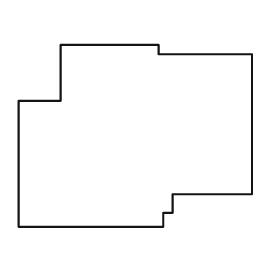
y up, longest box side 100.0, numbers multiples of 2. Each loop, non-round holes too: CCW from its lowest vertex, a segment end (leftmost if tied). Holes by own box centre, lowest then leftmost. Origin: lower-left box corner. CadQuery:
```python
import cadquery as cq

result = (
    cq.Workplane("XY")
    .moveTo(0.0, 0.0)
    .lineTo(62.0, 0.0)
    .lineTo(62.0, 6.0)
    .lineTo(66.0, 6.0)
    .lineTo(66.0, 14.0)
    .lineTo(100.0, 14.0)
    .lineTo(100.0, 74.0)
    .lineTo(60.0, 74.0)
    .lineTo(60.0, 78.0)
    .lineTo(18.0, 78.0)
    .lineTo(18.0, 54.0)
    .lineTo(0.0, 54.0)
    .close()
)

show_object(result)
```